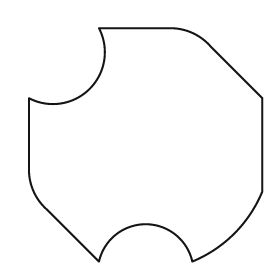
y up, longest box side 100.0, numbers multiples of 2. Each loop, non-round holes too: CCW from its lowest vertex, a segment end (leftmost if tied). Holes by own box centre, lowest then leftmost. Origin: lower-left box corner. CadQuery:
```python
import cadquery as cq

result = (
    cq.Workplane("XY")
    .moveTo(30.0, 0.0)
    .threePointArc((50.0, 16.0), (70.0, 0.0))
    .threePointArc((88.0, 12.0), (100.0, 30.0))
    .lineTo(100.0, 70.0)
    .lineTo(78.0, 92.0)
    .threePointArc((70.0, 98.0), (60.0, 100.0))
    .lineTo(30.0, 100.0)
    .threePointArc((26.0, 74.0), (0.0, 70.0))
    .lineTo(0.0, 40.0)
    .threePointArc((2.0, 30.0), (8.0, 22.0))
    .close()
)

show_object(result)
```